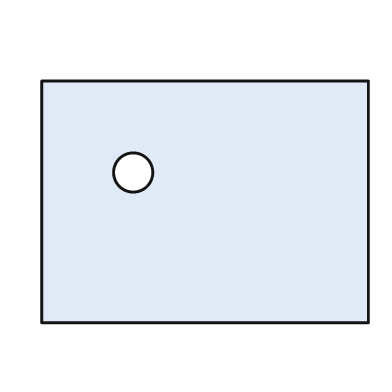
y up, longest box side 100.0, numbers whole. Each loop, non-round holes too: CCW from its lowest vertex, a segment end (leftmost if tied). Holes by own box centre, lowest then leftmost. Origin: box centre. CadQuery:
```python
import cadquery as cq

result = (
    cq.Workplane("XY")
    .moveTo(-50.0, -37.0)
    .lineTo(50.0, -37.0)
    .lineTo(50.0, 37.0)
    .lineTo(-50.0, 37.0)
    .close()
    .moveTo(-22.0, 9.0)
    .circle(6.0)
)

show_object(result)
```